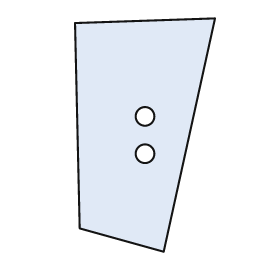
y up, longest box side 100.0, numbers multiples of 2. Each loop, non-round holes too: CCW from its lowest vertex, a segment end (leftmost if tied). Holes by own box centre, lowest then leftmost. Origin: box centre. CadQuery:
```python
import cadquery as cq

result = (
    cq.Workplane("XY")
    .moveTo(8.0, -50.0)
    .lineTo(30.0, 50.0)
    .lineTo(-30.0, 48.0)
    .lineTo(-28.0, -40.0)
    .close()
    .moveTo(0.0, -8.0)
    .circle(4.0)
    .moveTo(0.0, 8.0)
    .circle(4.0)
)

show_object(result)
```